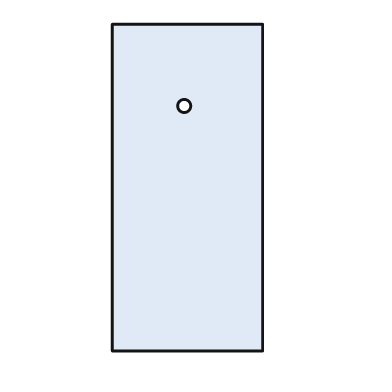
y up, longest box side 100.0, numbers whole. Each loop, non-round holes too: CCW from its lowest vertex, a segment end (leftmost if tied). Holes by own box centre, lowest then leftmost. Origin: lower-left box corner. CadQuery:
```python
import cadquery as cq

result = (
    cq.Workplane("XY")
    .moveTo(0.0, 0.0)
    .lineTo(46.0, 0.0)
    .lineTo(46.0, 100.0)
    .lineTo(0.0, 100.0)
    .close()
    .moveTo(22.0, 75.0)
    .circle(2.0)
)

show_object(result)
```